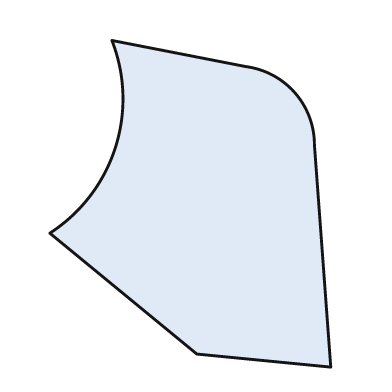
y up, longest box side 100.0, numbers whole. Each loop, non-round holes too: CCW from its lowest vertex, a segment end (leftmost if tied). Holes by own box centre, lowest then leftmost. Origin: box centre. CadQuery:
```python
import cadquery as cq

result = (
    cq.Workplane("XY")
    .moveTo(43.0, -50.0)
    .lineTo(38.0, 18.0)
    .threePointArc((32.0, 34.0), (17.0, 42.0))
    .lineTo(-24.0, 50.0)
    .threePointArc((-23.0, 17.0), (-43.0, -9.0))
    .lineTo(2.0, -46.0)
    .close()
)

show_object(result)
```